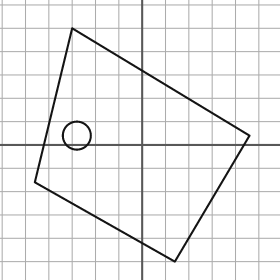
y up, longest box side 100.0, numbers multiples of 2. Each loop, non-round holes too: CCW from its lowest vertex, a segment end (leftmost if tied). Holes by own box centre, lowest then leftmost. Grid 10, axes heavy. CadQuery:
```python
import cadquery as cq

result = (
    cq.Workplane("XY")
    .moveTo(14.0, -50.0)
    .lineTo(46.0, 4.0)
    .lineTo(-30.0, 50.0)
    .lineTo(-46.0, -16.0)
    .close()
    .moveTo(-28.0, 4.0)
    .circle(6.0)
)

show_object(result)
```